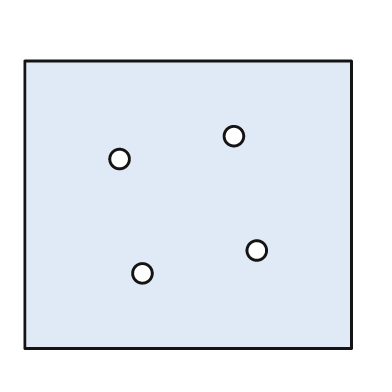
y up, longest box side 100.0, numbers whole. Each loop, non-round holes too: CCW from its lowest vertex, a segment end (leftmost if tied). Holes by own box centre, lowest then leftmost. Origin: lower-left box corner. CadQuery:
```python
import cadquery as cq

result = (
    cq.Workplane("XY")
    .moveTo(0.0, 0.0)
    .lineTo(100.0, 0.0)
    .lineTo(100.0, 88.0)
    .lineTo(0.0, 88.0)
    .close()
    .moveTo(36.0, 23.0)
    .circle(3.0)
    .moveTo(71.0, 30.0)
    .circle(3.0)
    .moveTo(29.0, 58.0)
    .circle(3.0)
    .moveTo(64.0, 65.0)
    .circle(3.0)
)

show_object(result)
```